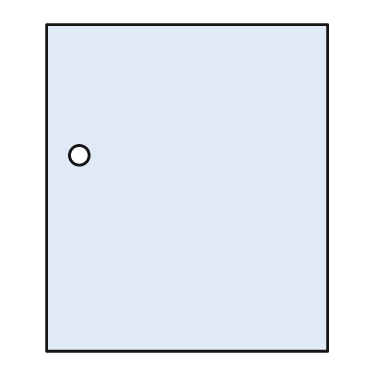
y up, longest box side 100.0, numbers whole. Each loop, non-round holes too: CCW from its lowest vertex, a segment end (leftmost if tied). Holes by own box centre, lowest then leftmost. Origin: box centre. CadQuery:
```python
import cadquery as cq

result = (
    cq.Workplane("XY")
    .moveTo(-43.0, -50.0)
    .lineTo(43.0, -50.0)
    .lineTo(43.0, 50.0)
    .lineTo(-43.0, 50.0)
    .close()
    .moveTo(-33.0, 10.0)
    .circle(3.0)
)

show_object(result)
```